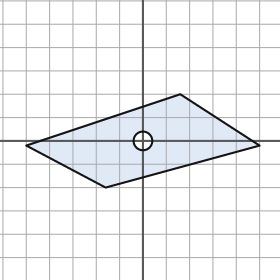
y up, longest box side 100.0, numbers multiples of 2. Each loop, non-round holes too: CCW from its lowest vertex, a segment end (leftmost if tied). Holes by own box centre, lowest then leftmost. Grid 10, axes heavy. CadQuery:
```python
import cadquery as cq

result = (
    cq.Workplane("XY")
    .moveTo(-16.0, -20.0)
    .lineTo(50.0, -2.0)
    .lineTo(16.0, 20.0)
    .lineTo(-50.0, -2.0)
    .close()
    .moveTo(0.0, 0.0)
    .circle(4.0)
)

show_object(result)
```